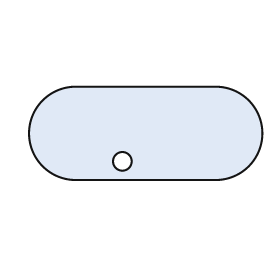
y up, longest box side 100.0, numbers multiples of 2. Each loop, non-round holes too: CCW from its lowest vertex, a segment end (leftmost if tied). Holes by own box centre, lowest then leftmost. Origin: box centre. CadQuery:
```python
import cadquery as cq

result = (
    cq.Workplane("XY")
    .moveTo(-30.0, -20.0)
    .lineTo(30.0, -20.0)
    .threePointArc((50.0, 0.0), (30.0, 20.0))
    .lineTo(-30.0, 20.0)
    .threePointArc((-50.0, 0.0), (-30.0, -20.0))
    .close()
    .moveTo(-10.0, -12.0)
    .circle(4.0)
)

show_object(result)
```